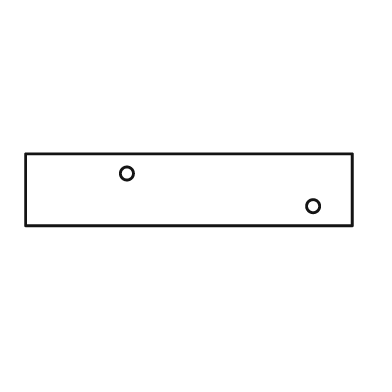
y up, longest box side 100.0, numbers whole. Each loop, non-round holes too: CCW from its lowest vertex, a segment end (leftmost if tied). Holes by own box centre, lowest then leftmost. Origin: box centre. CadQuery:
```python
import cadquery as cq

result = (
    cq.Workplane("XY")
    .moveTo(-50.0, -11.0)
    .lineTo(50.0, -11.0)
    .lineTo(50.0, 11.0)
    .lineTo(-50.0, 11.0)
    .close()
    .moveTo(38.0, -5.0)
    .circle(2.0)
    .moveTo(-19.0, 5.0)
    .circle(2.0)
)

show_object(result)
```